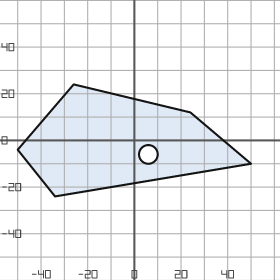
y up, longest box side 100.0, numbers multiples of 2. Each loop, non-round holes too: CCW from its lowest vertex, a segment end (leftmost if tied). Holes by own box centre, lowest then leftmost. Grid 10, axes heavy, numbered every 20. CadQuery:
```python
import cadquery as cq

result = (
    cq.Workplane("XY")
    .moveTo(-34.0, -24.0)
    .lineTo(50.0, -10.0)
    .lineTo(24.0, 12.0)
    .lineTo(-26.0, 24.0)
    .lineTo(-50.0, -4.0)
    .close()
    .moveTo(6.0, -6.0)
    .circle(4.0)
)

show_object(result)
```